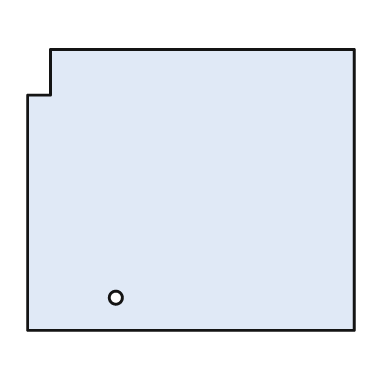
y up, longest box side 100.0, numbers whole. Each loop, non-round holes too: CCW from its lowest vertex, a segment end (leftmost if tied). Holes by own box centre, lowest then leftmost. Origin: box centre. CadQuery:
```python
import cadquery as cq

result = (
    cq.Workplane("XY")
    .moveTo(-50.0, -43.0)
    .lineTo(50.0, -43.0)
    .lineTo(50.0, 43.0)
    .lineTo(-43.0, 43.0)
    .lineTo(-43.0, 29.0)
    .lineTo(-50.0, 29.0)
    .close()
    .moveTo(-23.0, -33.0)
    .circle(2.0)
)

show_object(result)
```